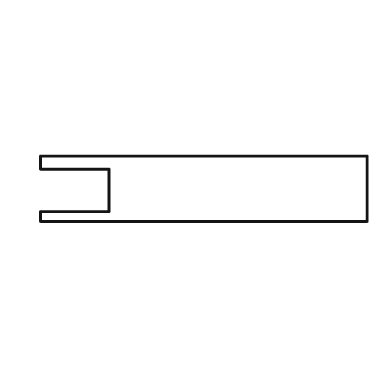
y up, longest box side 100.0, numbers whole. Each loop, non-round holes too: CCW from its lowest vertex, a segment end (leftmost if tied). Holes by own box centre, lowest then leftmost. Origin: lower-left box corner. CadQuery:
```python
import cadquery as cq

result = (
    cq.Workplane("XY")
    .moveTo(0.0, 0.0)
    .lineTo(100.0, 0.0)
    .lineTo(100.0, 20.0)
    .lineTo(0.0, 20.0)
    .lineTo(0.0, 16.0)
    .lineTo(21.0, 16.0)
    .lineTo(21.0, 3.0)
    .lineTo(0.0, 3.0)
    .close()
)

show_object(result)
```